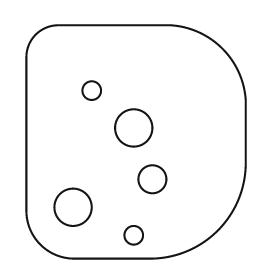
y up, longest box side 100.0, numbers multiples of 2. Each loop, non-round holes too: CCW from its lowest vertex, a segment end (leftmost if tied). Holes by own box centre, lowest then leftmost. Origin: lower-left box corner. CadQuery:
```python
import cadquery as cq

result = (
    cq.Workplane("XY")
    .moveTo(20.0, 0.0)
    .lineTo(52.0, 0.0)
    .threePointArc((82.0, 12.0), (94.0, 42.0))
    .lineTo(94.0, 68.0)
    .threePointArc((84.0, 90.0), (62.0, 100.0))
    .lineTo(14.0, 100.0)
    .threePointArc((4.0, 96.0), (0.0, 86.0))
    .lineTo(0.0, 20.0)
    .threePointArc((6.0, 6.0), (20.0, 0.0))
    .close()
    .moveTo(46.0, 10.0)
    .circle(4.0)
    .moveTo(20.0, 22.0)
    .circle(8.0)
    .moveTo(54.0, 34.0)
    .circle(6.0)
    .moveTo(46.0, 56.0)
    .circle(8.0)
    .moveTo(28.0, 72.0)
    .circle(4.0)
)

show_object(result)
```